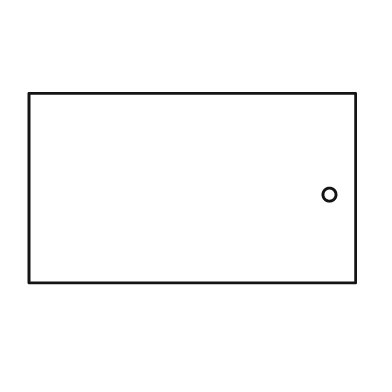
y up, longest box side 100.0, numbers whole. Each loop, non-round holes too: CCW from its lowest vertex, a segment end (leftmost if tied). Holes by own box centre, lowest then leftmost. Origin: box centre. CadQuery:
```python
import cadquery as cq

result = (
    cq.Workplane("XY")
    .moveTo(-50.0, -29.0)
    .lineTo(50.0, -29.0)
    .lineTo(50.0, 29.0)
    .lineTo(-50.0, 29.0)
    .close()
    .moveTo(42.0, -2.0)
    .circle(2.0)
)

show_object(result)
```